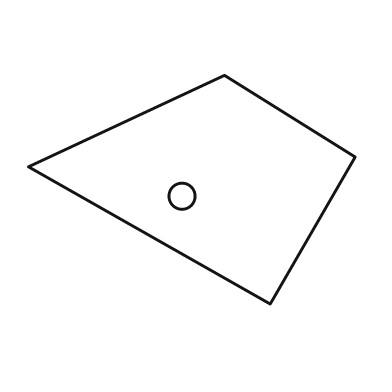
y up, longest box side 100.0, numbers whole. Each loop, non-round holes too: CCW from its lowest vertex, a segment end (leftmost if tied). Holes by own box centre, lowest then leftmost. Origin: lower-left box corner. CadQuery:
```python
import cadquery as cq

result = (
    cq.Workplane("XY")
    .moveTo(74.0, 0.0)
    .lineTo(100.0, 45.0)
    .lineTo(60.0, 70.0)
    .lineTo(0.0, 42.0)
    .close()
    .moveTo(47.0, 33.0)
    .circle(4.0)
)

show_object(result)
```